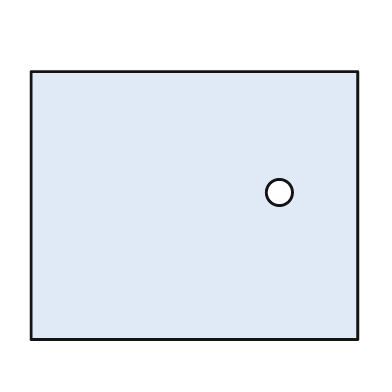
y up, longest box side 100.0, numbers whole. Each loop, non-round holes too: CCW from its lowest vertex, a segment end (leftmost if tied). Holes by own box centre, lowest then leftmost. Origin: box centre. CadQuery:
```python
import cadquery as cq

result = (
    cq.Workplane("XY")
    .moveTo(-50.0, -41.0)
    .lineTo(50.0, -41.0)
    .lineTo(50.0, 41.0)
    .lineTo(-50.0, 41.0)
    .close()
    .moveTo(26.0, 4.0)
    .circle(4.0)
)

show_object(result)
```